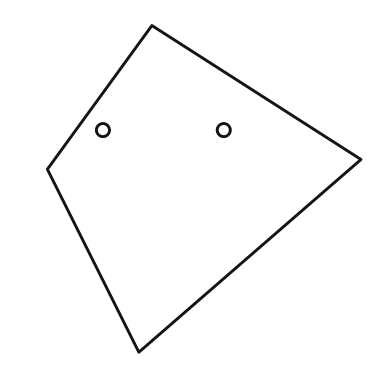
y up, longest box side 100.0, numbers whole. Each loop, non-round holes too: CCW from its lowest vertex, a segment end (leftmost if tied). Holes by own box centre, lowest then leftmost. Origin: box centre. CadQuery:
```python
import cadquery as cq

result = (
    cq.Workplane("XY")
    .moveTo(-20.0, -50.0)
    .lineTo(48.0, 9.0)
    .lineTo(-16.0, 50.0)
    .lineTo(-48.0, 6.0)
    .close()
    .moveTo(-31.0, 18.0)
    .circle(2.0)
    .moveTo(6.0, 18.0)
    .circle(2.0)
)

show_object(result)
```